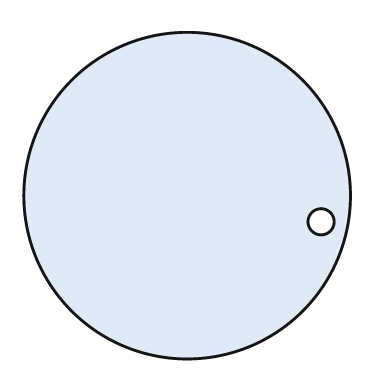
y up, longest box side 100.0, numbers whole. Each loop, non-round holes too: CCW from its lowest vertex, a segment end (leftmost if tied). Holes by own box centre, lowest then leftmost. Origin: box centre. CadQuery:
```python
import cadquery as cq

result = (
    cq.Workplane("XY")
    .moveTo(0.0, 0.0)
    .circle(50.0)
    .moveTo(41.0, -8.0)
    .circle(4.0)
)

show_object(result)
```